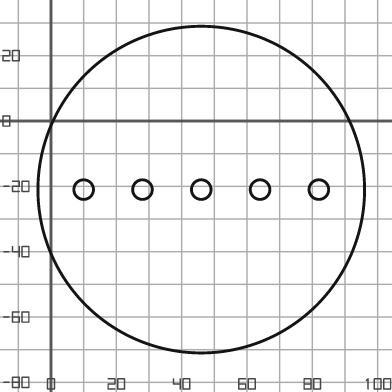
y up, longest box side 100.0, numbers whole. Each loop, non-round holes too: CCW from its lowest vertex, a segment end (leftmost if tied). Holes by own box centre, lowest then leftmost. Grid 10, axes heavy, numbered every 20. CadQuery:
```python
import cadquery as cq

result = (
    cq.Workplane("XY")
    .moveTo(46.0, -21.0)
    .circle(50.0)
    .moveTo(10.0, -21.0)
    .circle(3.0)
    .moveTo(28.0, -21.0)
    .circle(3.0)
    .moveTo(46.0, -21.0)
    .circle(3.0)
    .moveTo(64.0, -21.0)
    .circle(3.0)
    .moveTo(82.0, -21.0)
    .circle(3.0)
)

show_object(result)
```